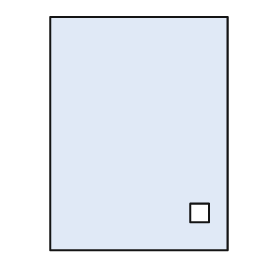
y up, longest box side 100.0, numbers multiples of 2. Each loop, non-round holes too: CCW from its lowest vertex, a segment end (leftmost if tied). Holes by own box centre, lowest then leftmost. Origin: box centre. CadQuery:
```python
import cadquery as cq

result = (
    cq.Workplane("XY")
    .moveTo(-38.0, -50.0)
    .lineTo(38.0, -50.0)
    .lineTo(38.0, 50.0)
    .lineTo(-38.0, 50.0)
    .close()
    .moveTo(22.0, -38.0)
    .lineTo(30.0, -38.0)
    .lineTo(30.0, -30.0)
    .lineTo(22.0, -30.0)
    .close()
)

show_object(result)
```